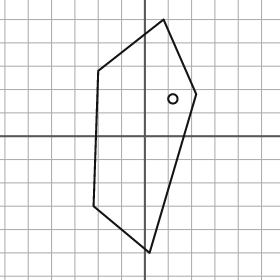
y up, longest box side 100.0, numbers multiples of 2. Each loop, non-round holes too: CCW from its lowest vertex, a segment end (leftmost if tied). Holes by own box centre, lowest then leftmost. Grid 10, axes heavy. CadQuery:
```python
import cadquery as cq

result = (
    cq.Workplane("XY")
    .moveTo(2.0, -50.0)
    .lineTo(22.0, 18.0)
    .lineTo(8.0, 50.0)
    .lineTo(-20.0, 28.0)
    .lineTo(-22.0, -30.0)
    .close()
    .moveTo(12.0, 16.0)
    .circle(2.0)
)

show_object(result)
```